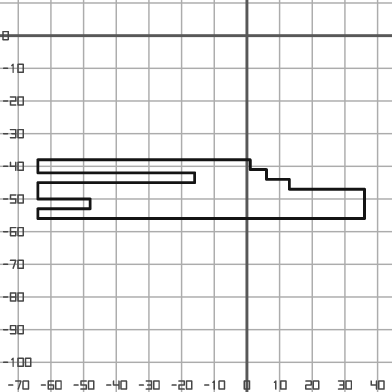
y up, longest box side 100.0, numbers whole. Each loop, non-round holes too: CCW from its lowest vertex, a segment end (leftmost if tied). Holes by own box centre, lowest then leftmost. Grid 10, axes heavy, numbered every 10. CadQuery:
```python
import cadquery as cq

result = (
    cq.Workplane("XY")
    .moveTo(-64.0, -56.0)
    .lineTo(36.0, -56.0)
    .lineTo(36.0, -47.0)
    .lineTo(13.0, -47.0)
    .lineTo(13.0, -44.0)
    .lineTo(6.0, -44.0)
    .lineTo(6.0, -41.0)
    .lineTo(1.0, -41.0)
    .lineTo(1.0, -38.0)
    .lineTo(-64.0, -38.0)
    .lineTo(-64.0, -42.0)
    .lineTo(-16.0, -42.0)
    .lineTo(-16.0, -45.0)
    .lineTo(-64.0, -45.0)
    .lineTo(-64.0, -50.0)
    .lineTo(-48.0, -50.0)
    .lineTo(-48.0, -53.0)
    .lineTo(-64.0, -53.0)
    .close()
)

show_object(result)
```